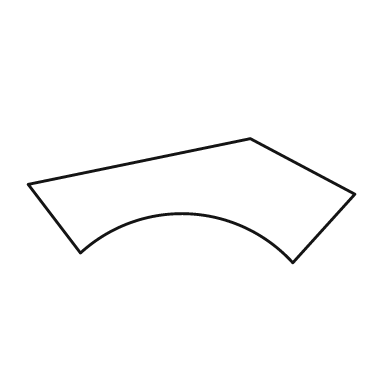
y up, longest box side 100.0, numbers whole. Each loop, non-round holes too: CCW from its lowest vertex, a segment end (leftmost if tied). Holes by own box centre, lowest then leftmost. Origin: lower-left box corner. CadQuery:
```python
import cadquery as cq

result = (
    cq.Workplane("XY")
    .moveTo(81.0, 0.0)
    .lineTo(100.0, 21.0)
    .lineTo(68.0, 38.0)
    .lineTo(0.0, 24.0)
    .lineTo(16.0, 3.0)
    .threePointArc((49.0, 15.0), (81.0, 0.0))
    .close()
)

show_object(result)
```